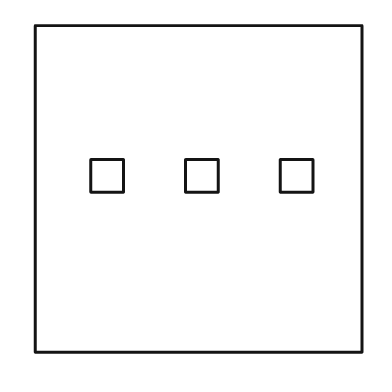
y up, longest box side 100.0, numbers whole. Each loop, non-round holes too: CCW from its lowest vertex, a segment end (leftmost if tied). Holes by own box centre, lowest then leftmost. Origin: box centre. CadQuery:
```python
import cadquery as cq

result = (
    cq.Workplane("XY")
    .moveTo(-50.0, -50.0)
    .lineTo(50.0, -50.0)
    .lineTo(50.0, 50.0)
    .lineTo(-50.0, 50.0)
    .close()
    .moveTo(-33.0, -1.0)
    .lineTo(-23.0, -1.0)
    .lineTo(-23.0, 9.0)
    .lineTo(-33.0, 9.0)
    .close()
    .moveTo(-4.0, -1.0)
    .lineTo(6.0, -1.0)
    .lineTo(6.0, 9.0)
    .lineTo(-4.0, 9.0)
    .close()
    .moveTo(25.0, -1.0)
    .lineTo(35.0, -1.0)
    .lineTo(35.0, 9.0)
    .lineTo(25.0, 9.0)
    .close()
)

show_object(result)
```